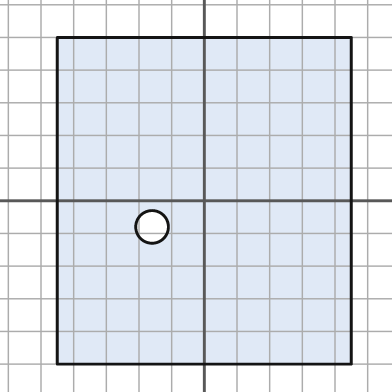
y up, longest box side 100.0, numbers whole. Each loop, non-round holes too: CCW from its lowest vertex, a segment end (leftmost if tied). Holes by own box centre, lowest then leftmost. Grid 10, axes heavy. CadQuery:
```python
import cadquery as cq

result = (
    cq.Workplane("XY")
    .moveTo(-45.0, -50.0)
    .lineTo(45.0, -50.0)
    .lineTo(45.0, 50.0)
    .lineTo(-45.0, 50.0)
    .close()
    .moveTo(-16.0, -8.0)
    .circle(5.0)
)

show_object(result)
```